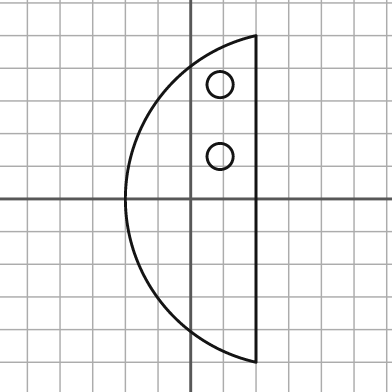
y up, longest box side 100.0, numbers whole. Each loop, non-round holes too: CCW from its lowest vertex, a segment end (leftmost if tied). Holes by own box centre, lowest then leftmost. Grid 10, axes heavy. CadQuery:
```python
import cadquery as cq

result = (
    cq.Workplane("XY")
    .moveTo(20.0, -50.0)
    .lineTo(20.0, 50.0)
    .threePointArc((-20.0, 0.0), (20.0, -50.0))
    .close()
    .moveTo(9.0, 13.0)
    .circle(4.0)
    .moveTo(9.0, 35.0)
    .circle(4.0)
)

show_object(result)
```